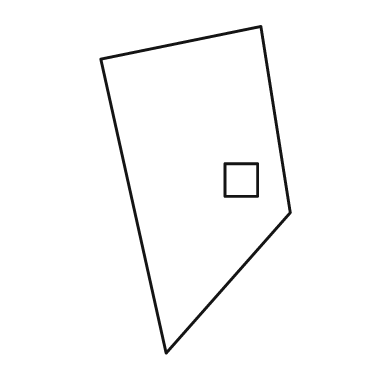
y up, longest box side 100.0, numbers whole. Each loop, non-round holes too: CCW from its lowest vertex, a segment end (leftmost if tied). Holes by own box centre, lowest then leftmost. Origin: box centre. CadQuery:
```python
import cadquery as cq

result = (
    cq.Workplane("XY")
    .moveTo(-9.0, -50.0)
    .lineTo(29.0, -7.0)
    .lineTo(20.0, 50.0)
    .lineTo(-29.0, 40.0)
    .close()
    .moveTo(9.0, -2.0)
    .lineTo(19.0, -2.0)
    .lineTo(19.0, 8.0)
    .lineTo(9.0, 8.0)
    .close()
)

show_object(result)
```